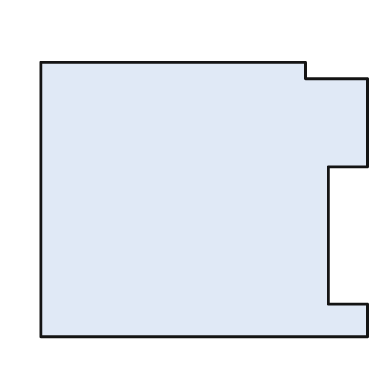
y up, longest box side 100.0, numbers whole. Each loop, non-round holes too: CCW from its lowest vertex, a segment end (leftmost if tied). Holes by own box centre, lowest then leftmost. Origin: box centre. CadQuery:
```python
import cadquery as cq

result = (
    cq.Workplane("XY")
    .moveTo(-50.0, -42.0)
    .lineTo(50.0, -42.0)
    .lineTo(50.0, -32.0)
    .lineTo(38.0, -32.0)
    .lineTo(38.0, 10.0)
    .lineTo(50.0, 10.0)
    .lineTo(50.0, 37.0)
    .lineTo(31.0, 37.0)
    .lineTo(31.0, 42.0)
    .lineTo(-50.0, 42.0)
    .close()
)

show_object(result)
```